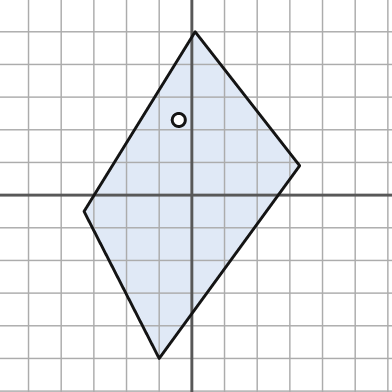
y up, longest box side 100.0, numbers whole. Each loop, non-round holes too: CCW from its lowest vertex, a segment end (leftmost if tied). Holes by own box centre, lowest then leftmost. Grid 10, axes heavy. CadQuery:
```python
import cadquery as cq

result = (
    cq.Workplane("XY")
    .moveTo(-10.0, -50.0)
    .lineTo(33.0, 9.0)
    .lineTo(1.0, 50.0)
    .lineTo(-33.0, -5.0)
    .close()
    .moveTo(-4.0, 23.0)
    .circle(2.0)
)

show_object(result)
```